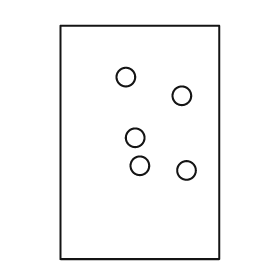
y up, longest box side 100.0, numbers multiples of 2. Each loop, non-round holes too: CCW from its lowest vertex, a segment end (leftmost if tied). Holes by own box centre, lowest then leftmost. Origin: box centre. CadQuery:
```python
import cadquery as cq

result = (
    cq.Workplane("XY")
    .moveTo(-34.0, -50.0)
    .lineTo(34.0, -50.0)
    .lineTo(34.0, 50.0)
    .lineTo(-34.0, 50.0)
    .close()
    .moveTo(20.0, -12.0)
    .circle(4.0)
    .moveTo(0.0, -10.0)
    .circle(4.0)
    .moveTo(-2.0, 2.0)
    .circle(4.0)
    .moveTo(18.0, 20.0)
    .circle(4.0)
    .moveTo(-6.0, 28.0)
    .circle(4.0)
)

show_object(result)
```